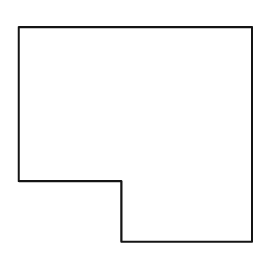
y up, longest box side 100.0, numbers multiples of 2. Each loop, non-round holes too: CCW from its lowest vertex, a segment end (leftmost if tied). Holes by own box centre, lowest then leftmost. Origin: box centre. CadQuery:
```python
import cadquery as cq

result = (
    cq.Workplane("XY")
    .moveTo(-6.0, -46.0)
    .lineTo(50.0, -46.0)
    .lineTo(50.0, 46.0)
    .lineTo(-50.0, 46.0)
    .lineTo(-50.0, -20.0)
    .lineTo(-6.0, -20.0)
    .close()
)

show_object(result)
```